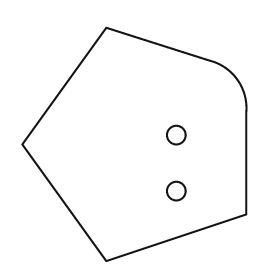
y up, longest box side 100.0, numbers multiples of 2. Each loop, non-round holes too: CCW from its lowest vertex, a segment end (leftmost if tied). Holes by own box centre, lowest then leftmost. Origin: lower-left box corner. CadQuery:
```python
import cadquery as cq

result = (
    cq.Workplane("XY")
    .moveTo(36.0, 0.0)
    .lineTo(96.0, 20.0)
    .lineTo(96.0, 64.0)
    .threePointArc((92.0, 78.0), (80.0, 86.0))
    .lineTo(36.0, 100.0)
    .lineTo(0.0, 50.0)
    .close()
    .moveTo(66.0, 30.0)
    .circle(4.0)
    .moveTo(66.0, 54.0)
    .circle(4.0)
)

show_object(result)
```